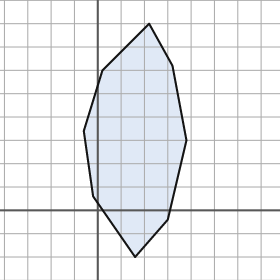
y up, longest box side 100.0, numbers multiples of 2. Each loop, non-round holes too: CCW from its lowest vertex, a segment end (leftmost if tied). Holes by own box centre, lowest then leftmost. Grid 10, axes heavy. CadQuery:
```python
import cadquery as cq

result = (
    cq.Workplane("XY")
    .moveTo(16.0, -20.0)
    .lineTo(30.0, -4.0)
    .lineTo(38.0, 30.0)
    .lineTo(32.0, 62.0)
    .lineTo(22.0, 80.0)
    .lineTo(2.0, 60.0)
    .lineTo(-6.0, 34.0)
    .lineTo(-2.0, 6.0)
    .close()
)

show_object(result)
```